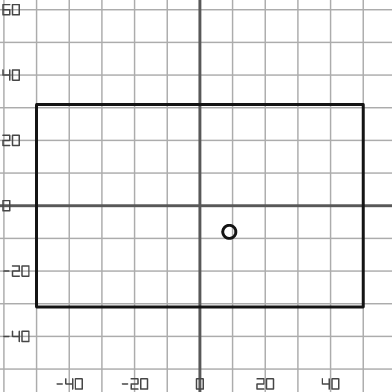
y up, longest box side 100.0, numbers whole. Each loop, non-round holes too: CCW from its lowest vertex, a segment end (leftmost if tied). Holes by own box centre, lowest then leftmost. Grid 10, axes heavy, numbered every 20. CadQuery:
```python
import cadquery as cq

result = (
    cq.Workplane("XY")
    .moveTo(-50.0, -31.0)
    .lineTo(50.0, -31.0)
    .lineTo(50.0, 31.0)
    .lineTo(-50.0, 31.0)
    .close()
    .moveTo(9.0, -8.0)
    .circle(2.0)
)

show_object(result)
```